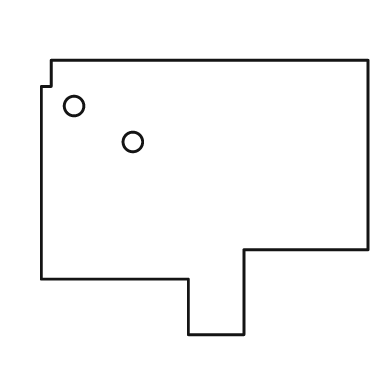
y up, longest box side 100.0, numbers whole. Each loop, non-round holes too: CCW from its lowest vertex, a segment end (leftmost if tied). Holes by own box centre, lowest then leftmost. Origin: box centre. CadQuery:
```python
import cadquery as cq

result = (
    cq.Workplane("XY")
    .moveTo(-5.0, -42.0)
    .lineTo(12.0, -42.0)
    .lineTo(12.0, -16.0)
    .lineTo(50.0, -16.0)
    .lineTo(50.0, 42.0)
    .lineTo(-47.0, 42.0)
    .lineTo(-47.0, 34.0)
    .lineTo(-50.0, 34.0)
    .lineTo(-50.0, -25.0)
    .lineTo(-5.0, -25.0)
    .close()
    .moveTo(-22.0, 17.0)
    .circle(3.0)
    .moveTo(-40.0, 28.0)
    .circle(3.0)
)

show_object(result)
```